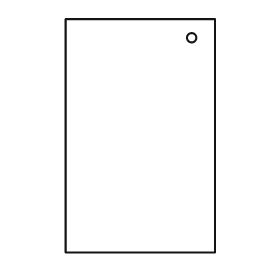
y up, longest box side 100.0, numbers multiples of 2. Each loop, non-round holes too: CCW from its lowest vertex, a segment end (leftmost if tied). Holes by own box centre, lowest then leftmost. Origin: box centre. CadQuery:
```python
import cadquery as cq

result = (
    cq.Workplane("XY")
    .moveTo(-32.0, -50.0)
    .lineTo(32.0, -50.0)
    .lineTo(32.0, 50.0)
    .lineTo(-32.0, 50.0)
    .close()
    .moveTo(22.0, 42.0)
    .circle(2.0)
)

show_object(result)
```